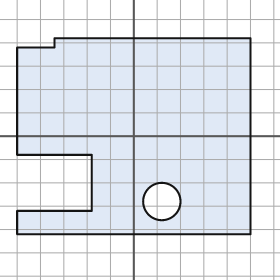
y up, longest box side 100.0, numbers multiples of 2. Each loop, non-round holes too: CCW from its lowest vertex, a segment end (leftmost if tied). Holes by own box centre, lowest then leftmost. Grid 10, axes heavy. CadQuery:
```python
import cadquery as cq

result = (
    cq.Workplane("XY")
    .moveTo(-50.0, -42.0)
    .lineTo(50.0, -42.0)
    .lineTo(50.0, 42.0)
    .lineTo(-34.0, 42.0)
    .lineTo(-34.0, 38.0)
    .lineTo(-50.0, 38.0)
    .lineTo(-50.0, -8.0)
    .lineTo(-18.0, -8.0)
    .lineTo(-18.0, -32.0)
    .lineTo(-50.0, -32.0)
    .close()
    .moveTo(12.0, -28.0)
    .circle(8.0)
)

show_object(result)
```